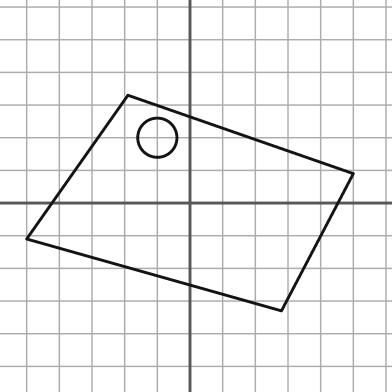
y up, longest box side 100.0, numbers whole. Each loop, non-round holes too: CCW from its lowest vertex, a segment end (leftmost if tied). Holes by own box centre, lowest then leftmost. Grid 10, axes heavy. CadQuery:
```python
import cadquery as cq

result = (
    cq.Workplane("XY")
    .moveTo(28.0, -33.0)
    .lineTo(50.0, 9.0)
    .lineTo(-19.0, 33.0)
    .lineTo(-50.0, -11.0)
    .close()
    .moveTo(-10.0, 20.0)
    .circle(6.0)
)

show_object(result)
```